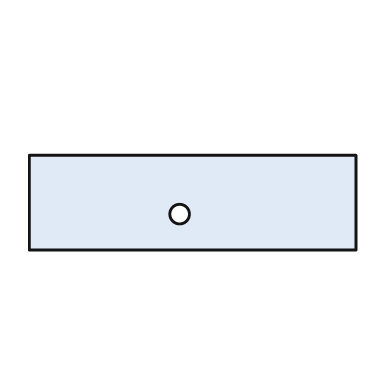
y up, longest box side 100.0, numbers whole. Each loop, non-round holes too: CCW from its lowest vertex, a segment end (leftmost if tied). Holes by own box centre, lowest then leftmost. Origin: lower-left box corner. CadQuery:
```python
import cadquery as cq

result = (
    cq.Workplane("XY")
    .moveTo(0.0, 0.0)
    .lineTo(100.0, 0.0)
    .lineTo(100.0, 29.0)
    .lineTo(0.0, 29.0)
    .close()
    .moveTo(46.0, 11.0)
    .circle(3.0)
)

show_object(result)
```